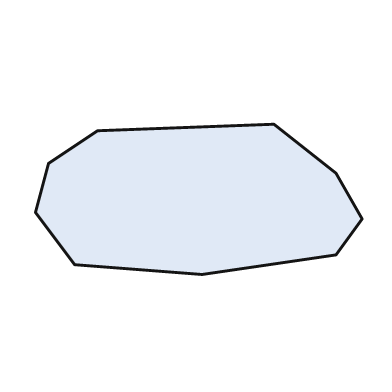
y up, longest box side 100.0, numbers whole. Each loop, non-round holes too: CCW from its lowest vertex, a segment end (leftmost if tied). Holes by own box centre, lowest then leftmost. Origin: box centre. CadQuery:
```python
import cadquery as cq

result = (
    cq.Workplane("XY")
    .moveTo(1.0, -23.0)
    .lineTo(42.0, -17.0)
    .lineTo(50.0, -6.0)
    .lineTo(42.0, 8.0)
    .lineTo(23.0, 23.0)
    .lineTo(-31.0, 21.0)
    .lineTo(-46.0, 11.0)
    .lineTo(-50.0, -4.0)
    .lineTo(-38.0, -20.0)
    .close()
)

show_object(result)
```